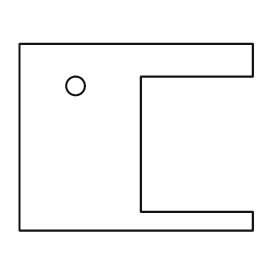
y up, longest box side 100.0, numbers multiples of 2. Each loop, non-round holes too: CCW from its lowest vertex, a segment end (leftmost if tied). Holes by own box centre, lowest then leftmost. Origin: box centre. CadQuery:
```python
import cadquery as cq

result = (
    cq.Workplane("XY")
    .moveTo(-50.0, -40.0)
    .lineTo(50.0, -40.0)
    .lineTo(50.0, -32.0)
    .lineTo(2.0, -32.0)
    .lineTo(2.0, 26.0)
    .lineTo(50.0, 26.0)
    .lineTo(50.0, 40.0)
    .lineTo(-50.0, 40.0)
    .close()
    .moveTo(-26.0, 22.0)
    .circle(4.0)
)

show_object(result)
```